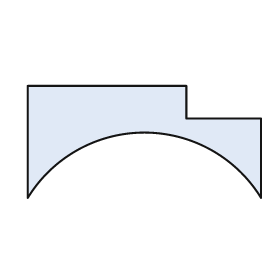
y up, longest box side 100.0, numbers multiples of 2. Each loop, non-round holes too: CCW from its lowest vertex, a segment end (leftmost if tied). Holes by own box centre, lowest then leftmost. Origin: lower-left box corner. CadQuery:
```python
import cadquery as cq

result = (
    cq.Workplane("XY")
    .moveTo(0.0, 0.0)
    .threePointArc((50.0, 28.0), (100.0, 0.0))
    .lineTo(100.0, 34.0)
    .lineTo(68.0, 34.0)
    .lineTo(68.0, 48.0)
    .lineTo(0.0, 48.0)
    .close()
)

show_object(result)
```